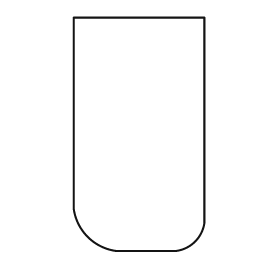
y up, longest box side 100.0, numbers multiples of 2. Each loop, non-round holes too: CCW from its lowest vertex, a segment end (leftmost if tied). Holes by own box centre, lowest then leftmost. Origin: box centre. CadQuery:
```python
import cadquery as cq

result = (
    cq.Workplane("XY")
    .moveTo(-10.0, -50.0)
    .lineTo(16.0, -50.0)
    .threePointArc((24.0, -46.0), (28.0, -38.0))
    .lineTo(28.0, 50.0)
    .lineTo(-28.0, 50.0)
    .lineTo(-28.0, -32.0)
    .threePointArc((-22.0, -44.0), (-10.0, -50.0))
    .close()
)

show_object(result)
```